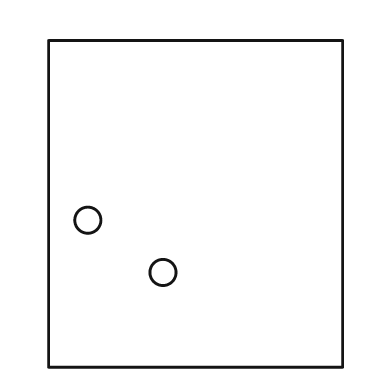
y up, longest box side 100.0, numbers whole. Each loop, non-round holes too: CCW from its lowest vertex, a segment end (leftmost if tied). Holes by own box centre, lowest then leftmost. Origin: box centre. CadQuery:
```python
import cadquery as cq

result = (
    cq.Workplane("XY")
    .moveTo(-45.0, -50.0)
    .lineTo(45.0, -50.0)
    .lineTo(45.0, 50.0)
    .lineTo(-45.0, 50.0)
    .close()
    .moveTo(-10.0, -21.0)
    .circle(4.0)
    .moveTo(-33.0, -5.0)
    .circle(4.0)
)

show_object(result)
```